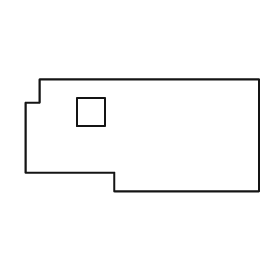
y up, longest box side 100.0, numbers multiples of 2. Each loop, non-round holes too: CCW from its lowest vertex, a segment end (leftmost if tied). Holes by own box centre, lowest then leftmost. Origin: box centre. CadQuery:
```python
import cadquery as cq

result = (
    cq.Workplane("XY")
    .moveTo(-12.0, -24.0)
    .lineTo(50.0, -24.0)
    .lineTo(50.0, 24.0)
    .lineTo(-44.0, 24.0)
    .lineTo(-44.0, 14.0)
    .lineTo(-50.0, 14.0)
    .lineTo(-50.0, -16.0)
    .lineTo(-12.0, -16.0)
    .close()
    .moveTo(-28.0, 4.0)
    .lineTo(-16.0, 4.0)
    .lineTo(-16.0, 16.0)
    .lineTo(-28.0, 16.0)
    .close()
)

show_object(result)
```